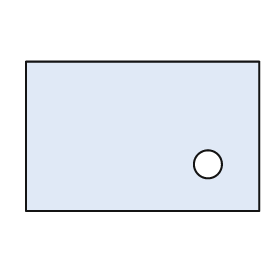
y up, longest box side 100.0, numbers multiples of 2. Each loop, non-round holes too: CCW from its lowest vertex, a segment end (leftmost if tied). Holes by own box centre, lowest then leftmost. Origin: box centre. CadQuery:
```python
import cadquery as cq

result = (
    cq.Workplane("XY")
    .moveTo(-50.0, -32.0)
    .lineTo(50.0, -32.0)
    .lineTo(50.0, 32.0)
    .lineTo(-50.0, 32.0)
    .close()
    .moveTo(28.0, -12.0)
    .circle(6.0)
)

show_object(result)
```